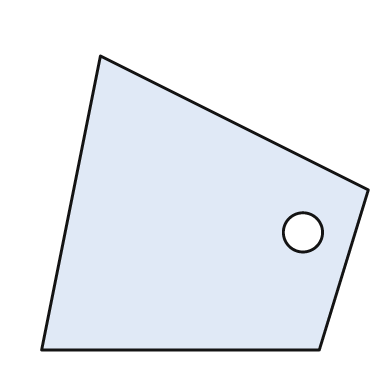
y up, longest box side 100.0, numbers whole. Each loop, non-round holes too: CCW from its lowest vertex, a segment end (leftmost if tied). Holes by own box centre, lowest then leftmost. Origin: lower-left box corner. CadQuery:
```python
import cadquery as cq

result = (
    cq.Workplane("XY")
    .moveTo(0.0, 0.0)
    .lineTo(85.0, 0.0)
    .lineTo(100.0, 49.0)
    .lineTo(18.0, 90.0)
    .close()
    .moveTo(80.0, 36.0)
    .circle(6.0)
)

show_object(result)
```